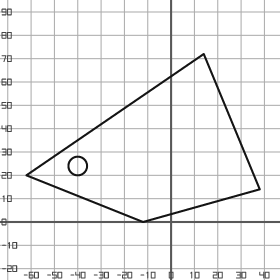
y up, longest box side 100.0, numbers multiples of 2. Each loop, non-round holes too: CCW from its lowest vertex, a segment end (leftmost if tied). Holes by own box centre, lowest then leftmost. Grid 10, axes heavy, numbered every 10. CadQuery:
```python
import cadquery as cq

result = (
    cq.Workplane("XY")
    .moveTo(-12.0, 0.0)
    .lineTo(38.0, 14.0)
    .lineTo(14.0, 72.0)
    .lineTo(-62.0, 20.0)
    .close()
    .moveTo(-40.0, 24.0)
    .circle(4.0)
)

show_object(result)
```